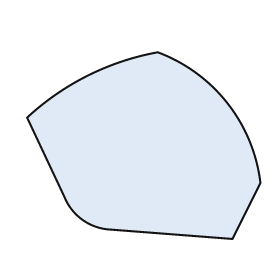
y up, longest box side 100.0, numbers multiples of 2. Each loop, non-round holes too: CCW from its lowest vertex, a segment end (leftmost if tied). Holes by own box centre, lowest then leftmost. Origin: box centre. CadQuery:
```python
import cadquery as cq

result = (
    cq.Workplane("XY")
    .moveTo(38.0, -40.0)
    .lineTo(50.0, -16.0)
    .threePointArc((36.0, 18.0), (6.0, 40.0))
    .threePointArc((-24.0, 30.0), (-50.0, 12.0))
    .lineTo(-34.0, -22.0)
    .threePointArc((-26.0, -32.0), (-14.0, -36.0))
    .close()
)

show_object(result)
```